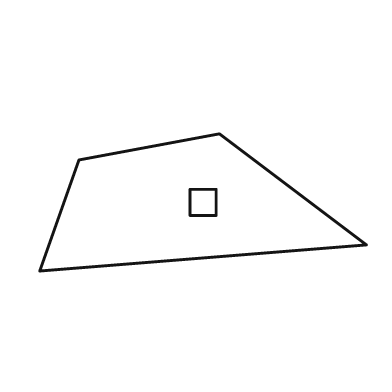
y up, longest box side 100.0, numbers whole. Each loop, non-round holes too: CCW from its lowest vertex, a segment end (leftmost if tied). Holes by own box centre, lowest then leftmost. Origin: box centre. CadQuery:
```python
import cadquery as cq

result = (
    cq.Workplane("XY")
    .moveTo(-50.0, -21.0)
    .lineTo(50.0, -13.0)
    .lineTo(5.0, 21.0)
    .lineTo(-38.0, 13.0)
    .close()
    .moveTo(-4.0, -4.0)
    .lineTo(4.0, -4.0)
    .lineTo(4.0, 4.0)
    .lineTo(-4.0, 4.0)
    .close()
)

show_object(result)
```